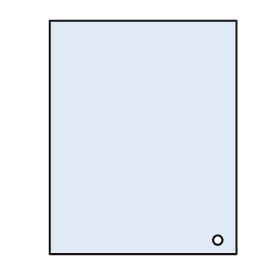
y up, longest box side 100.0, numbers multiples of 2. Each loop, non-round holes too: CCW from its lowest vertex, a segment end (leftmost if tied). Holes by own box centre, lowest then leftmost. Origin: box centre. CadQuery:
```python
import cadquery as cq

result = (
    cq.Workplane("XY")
    .moveTo(-40.0, -50.0)
    .lineTo(40.0, -50.0)
    .lineTo(40.0, 50.0)
    .lineTo(-40.0, 50.0)
    .close()
    .moveTo(32.0, -44.0)
    .circle(2.0)
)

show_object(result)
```